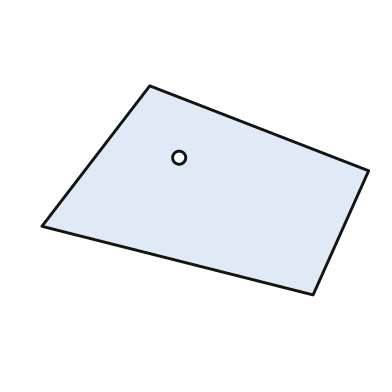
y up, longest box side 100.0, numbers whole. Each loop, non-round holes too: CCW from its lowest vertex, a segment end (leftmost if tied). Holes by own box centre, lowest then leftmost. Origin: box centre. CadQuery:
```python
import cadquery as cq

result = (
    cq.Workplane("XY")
    .moveTo(33.0, -32.0)
    .lineTo(50.0, 6.0)
    .lineTo(-17.0, 32.0)
    .lineTo(-50.0, -11.0)
    .close()
    .moveTo(-8.0, 10.0)
    .circle(2.0)
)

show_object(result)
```